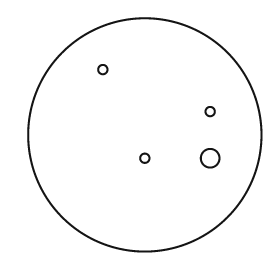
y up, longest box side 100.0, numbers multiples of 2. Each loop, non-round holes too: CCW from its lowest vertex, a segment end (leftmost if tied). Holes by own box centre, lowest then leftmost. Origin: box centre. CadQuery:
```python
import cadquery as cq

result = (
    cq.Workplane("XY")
    .moveTo(0.0, 0.0)
    .circle(50.0)
    .moveTo(0.0, -10.0)
    .circle(2.0)
    .moveTo(28.0, -10.0)
    .circle(4.0)
    .moveTo(28.0, 10.0)
    .circle(2.0)
    .moveTo(-18.0, 28.0)
    .circle(2.0)
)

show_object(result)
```